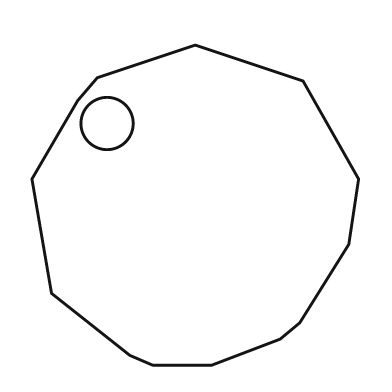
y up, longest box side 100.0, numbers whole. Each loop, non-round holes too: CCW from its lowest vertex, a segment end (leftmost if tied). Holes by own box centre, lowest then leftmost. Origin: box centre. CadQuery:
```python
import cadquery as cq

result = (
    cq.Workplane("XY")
    .moveTo(-13.0, -49.0)
    .lineTo(5.0, -49.0)
    .lineTo(26.0, -41.0)
    .lineTo(32.0, -36.0)
    .lineTo(47.0, -12.0)
    .lineTo(50.0, 8.0)
    .lineTo(33.0, 38.0)
    .lineTo(0.0, 49.0)
    .lineTo(-30.0, 39.0)
    .lineTo(-36.0, 32.0)
    .lineTo(-50.0, 8.0)
    .lineTo(-44.0, -27.0)
    .lineTo(-20.0, -46.0)
    .close()
    .moveTo(-27.0, 25.0)
    .circle(8.0)
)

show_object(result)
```